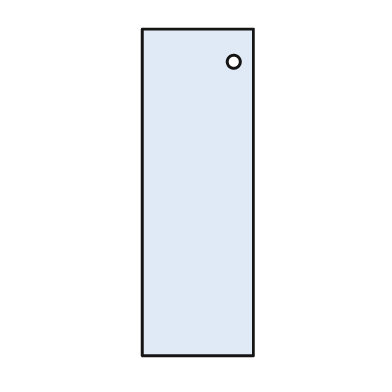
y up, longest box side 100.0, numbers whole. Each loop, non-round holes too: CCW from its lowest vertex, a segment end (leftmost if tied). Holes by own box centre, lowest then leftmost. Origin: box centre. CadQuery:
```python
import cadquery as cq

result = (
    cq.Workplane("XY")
    .moveTo(-17.0, -50.0)
    .lineTo(17.0, -50.0)
    .lineTo(17.0, 50.0)
    .lineTo(-17.0, 50.0)
    .close()
    .moveTo(11.0, 40.0)
    .circle(2.0)
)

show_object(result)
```